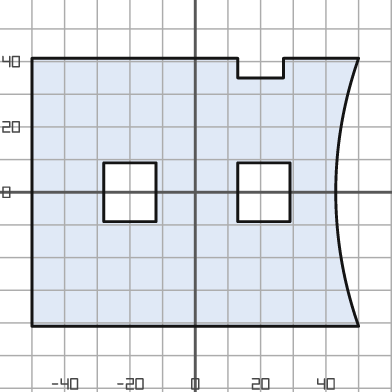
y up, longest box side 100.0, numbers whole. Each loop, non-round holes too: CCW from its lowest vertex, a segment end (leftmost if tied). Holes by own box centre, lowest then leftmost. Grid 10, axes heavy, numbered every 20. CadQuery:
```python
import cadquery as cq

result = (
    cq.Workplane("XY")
    .moveTo(-50.0, -41.0)
    .lineTo(50.0, -41.0)
    .threePointArc((43.0, 0.0), (50.0, 41.0))
    .lineTo(27.0, 41.0)
    .lineTo(27.0, 35.0)
    .lineTo(13.0, 35.0)
    .lineTo(13.0, 41.0)
    .lineTo(-50.0, 41.0)
    .close()
    .moveTo(-28.0, -9.0)
    .lineTo(-12.0, -9.0)
    .lineTo(-12.0, 9.0)
    .lineTo(-28.0, 9.0)
    .close()
    .moveTo(13.0, -9.0)
    .lineTo(29.0, -9.0)
    .lineTo(29.0, 9.0)
    .lineTo(13.0, 9.0)
    .close()
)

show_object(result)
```